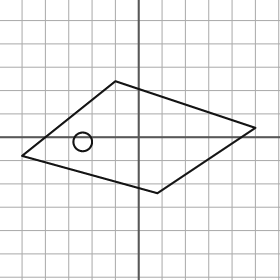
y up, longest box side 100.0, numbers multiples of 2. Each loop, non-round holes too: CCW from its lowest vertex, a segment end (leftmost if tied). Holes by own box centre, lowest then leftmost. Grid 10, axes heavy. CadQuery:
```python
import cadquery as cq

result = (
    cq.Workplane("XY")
    .moveTo(8.0, -24.0)
    .lineTo(50.0, 4.0)
    .lineTo(-10.0, 24.0)
    .lineTo(-50.0, -8.0)
    .close()
    .moveTo(-24.0, -2.0)
    .circle(4.0)
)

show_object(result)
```